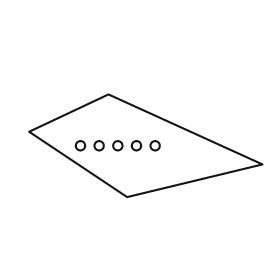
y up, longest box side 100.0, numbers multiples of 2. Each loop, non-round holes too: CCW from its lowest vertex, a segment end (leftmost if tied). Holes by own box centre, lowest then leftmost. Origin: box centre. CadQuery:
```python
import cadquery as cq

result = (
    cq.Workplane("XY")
    .moveTo(-8.0, -22.0)
    .lineTo(50.0, -8.0)
    .lineTo(-16.0, 22.0)
    .lineTo(-50.0, 6.0)
    .close()
    .moveTo(-28.0, 0.0)
    .circle(2.0)
    .moveTo(-20.0, 0.0)
    .circle(2.0)
    .moveTo(-12.0, 0.0)
    .circle(2.0)
    .moveTo(-4.0, 0.0)
    .circle(2.0)
    .moveTo(4.0, 0.0)
    .circle(2.0)
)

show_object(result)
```